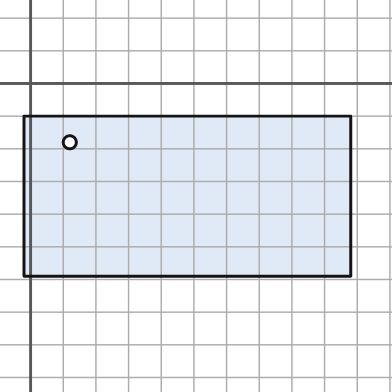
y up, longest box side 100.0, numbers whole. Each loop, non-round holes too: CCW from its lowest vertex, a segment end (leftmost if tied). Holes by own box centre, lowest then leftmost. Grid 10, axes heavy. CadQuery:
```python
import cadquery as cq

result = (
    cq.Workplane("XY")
    .moveTo(-2.0, -59.0)
    .lineTo(98.0, -59.0)
    .lineTo(98.0, -10.0)
    .lineTo(-2.0, -10.0)
    .close()
    .moveTo(12.0, -18.0)
    .circle(2.0)
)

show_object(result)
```